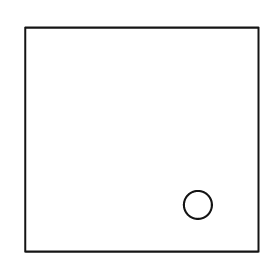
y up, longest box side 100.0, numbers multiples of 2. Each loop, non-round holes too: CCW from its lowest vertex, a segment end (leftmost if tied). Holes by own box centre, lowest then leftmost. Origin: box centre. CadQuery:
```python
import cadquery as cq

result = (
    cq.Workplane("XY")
    .moveTo(-50.0, -48.0)
    .lineTo(50.0, -48.0)
    .lineTo(50.0, 48.0)
    .lineTo(-50.0, 48.0)
    .close()
    .moveTo(24.0, -28.0)
    .circle(6.0)
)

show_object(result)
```